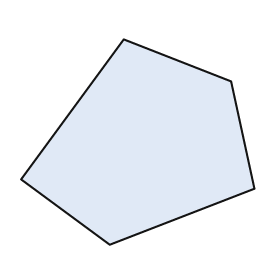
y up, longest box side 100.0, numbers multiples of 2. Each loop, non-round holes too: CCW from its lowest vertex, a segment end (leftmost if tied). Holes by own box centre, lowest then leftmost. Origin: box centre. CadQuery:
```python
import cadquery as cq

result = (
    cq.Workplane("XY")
    .moveTo(-12.0, -44.0)
    .lineTo(50.0, -20.0)
    .lineTo(40.0, 26.0)
    .lineTo(-6.0, 44.0)
    .lineTo(-50.0, -16.0)
    .close()
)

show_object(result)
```